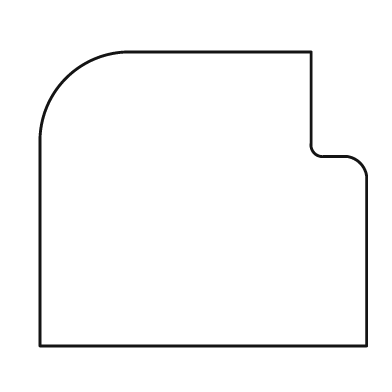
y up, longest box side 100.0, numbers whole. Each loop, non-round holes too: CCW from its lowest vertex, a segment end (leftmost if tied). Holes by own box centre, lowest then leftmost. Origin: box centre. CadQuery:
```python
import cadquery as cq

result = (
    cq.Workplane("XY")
    .moveTo(-50.0, -45.0)
    .lineTo(50.0, -45.0)
    .lineTo(50.0, 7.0)
    .threePointArc((48.0, 11.0), (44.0, 13.0))
    .lineTo(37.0, 13.0)
    .threePointArc((34.0, 14.0), (33.0, 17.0))
    .lineTo(33.0, 45.0)
    .lineTo(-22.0, 45.0)
    .threePointArc((-42.0, 37.0), (-50.0, 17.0))
    .close()
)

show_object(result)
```